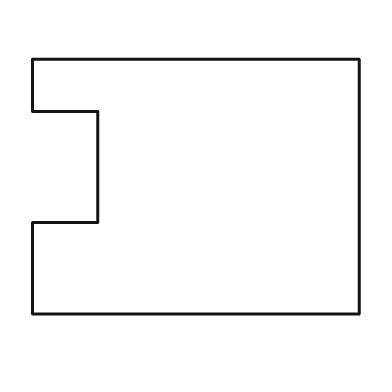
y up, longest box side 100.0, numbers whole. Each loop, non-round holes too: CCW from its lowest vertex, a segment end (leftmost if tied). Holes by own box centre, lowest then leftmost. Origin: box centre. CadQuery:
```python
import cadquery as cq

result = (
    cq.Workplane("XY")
    .moveTo(-50.0, -39.0)
    .lineTo(50.0, -39.0)
    .lineTo(50.0, 39.0)
    .lineTo(-50.0, 39.0)
    .lineTo(-50.0, 23.0)
    .lineTo(-30.0, 23.0)
    .lineTo(-30.0, -11.0)
    .lineTo(-50.0, -11.0)
    .close()
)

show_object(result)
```